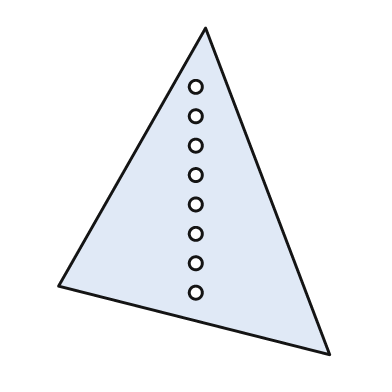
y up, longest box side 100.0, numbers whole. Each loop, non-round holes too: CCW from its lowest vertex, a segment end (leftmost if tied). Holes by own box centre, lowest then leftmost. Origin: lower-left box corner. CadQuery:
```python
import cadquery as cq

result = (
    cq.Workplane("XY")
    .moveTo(83.0, 0.0)
    .lineTo(45.0, 100.0)
    .lineTo(0.0, 21.0)
    .close()
    .moveTo(42.0, 19.0)
    .circle(2.0)
    .moveTo(42.0, 28.0)
    .circle(2.0)
    .moveTo(42.0, 37.0)
    .circle(2.0)
    .moveTo(42.0, 46.0)
    .circle(2.0)
    .moveTo(42.0, 55.0)
    .circle(2.0)
    .moveTo(42.0, 64.0)
    .circle(2.0)
    .moveTo(42.0, 73.0)
    .circle(2.0)
    .moveTo(42.0, 82.0)
    .circle(2.0)
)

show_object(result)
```